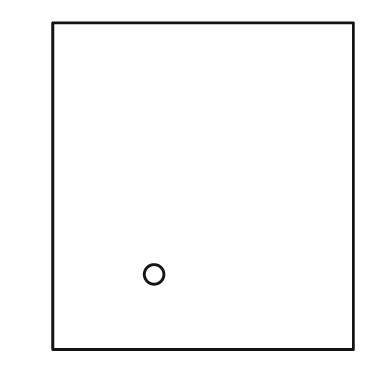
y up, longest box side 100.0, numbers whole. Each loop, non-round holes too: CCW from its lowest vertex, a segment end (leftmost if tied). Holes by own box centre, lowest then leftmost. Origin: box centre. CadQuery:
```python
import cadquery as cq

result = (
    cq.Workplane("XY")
    .moveTo(-46.0, -50.0)
    .lineTo(46.0, -50.0)
    .lineTo(46.0, 50.0)
    .lineTo(-46.0, 50.0)
    .close()
    .moveTo(-15.0, -27.0)
    .circle(3.0)
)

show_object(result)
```